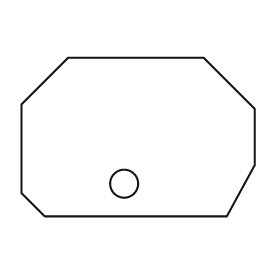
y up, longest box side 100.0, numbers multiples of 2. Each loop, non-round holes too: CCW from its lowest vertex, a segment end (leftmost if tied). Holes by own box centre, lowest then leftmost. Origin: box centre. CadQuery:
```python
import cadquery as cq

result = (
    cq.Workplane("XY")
    .moveTo(-40.0, -34.0)
    .lineTo(38.0, -34.0)
    .lineTo(50.0, -12.0)
    .lineTo(50.0, 12.0)
    .lineTo(28.0, 34.0)
    .lineTo(-30.0, 34.0)
    .lineTo(-50.0, 14.0)
    .lineTo(-50.0, -24.0)
    .close()
    .moveTo(-6.0, -20.0)
    .circle(6.0)
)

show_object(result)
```